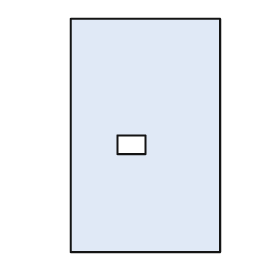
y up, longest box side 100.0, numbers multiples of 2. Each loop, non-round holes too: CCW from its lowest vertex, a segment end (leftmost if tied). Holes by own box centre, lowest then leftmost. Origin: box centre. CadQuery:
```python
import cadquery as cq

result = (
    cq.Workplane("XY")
    .moveTo(-32.0, -50.0)
    .lineTo(32.0, -50.0)
    .lineTo(32.0, 50.0)
    .lineTo(-32.0, 50.0)
    .close()
    .moveTo(-12.0, -8.0)
    .lineTo(0.0, -8.0)
    .lineTo(0.0, 0.0)
    .lineTo(-12.0, 0.0)
    .close()
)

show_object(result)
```